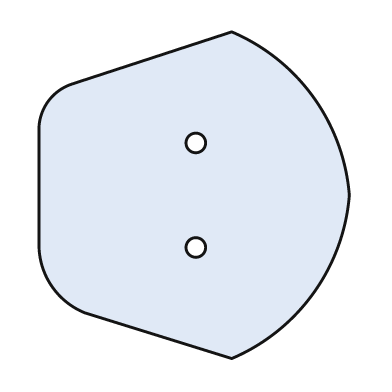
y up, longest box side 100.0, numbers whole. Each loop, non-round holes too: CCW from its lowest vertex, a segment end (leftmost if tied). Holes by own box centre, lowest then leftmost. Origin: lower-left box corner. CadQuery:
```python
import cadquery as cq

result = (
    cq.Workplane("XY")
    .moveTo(59.0, 0.0)
    .threePointArc((84.0, 20.0), (95.0, 50.0))
    .threePointArc((84.0, 80.0), (59.0, 100.0))
    .lineTo(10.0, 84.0)
    .threePointArc((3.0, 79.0), (0.0, 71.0))
    .lineTo(0.0, 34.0)
    .threePointArc((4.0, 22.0), (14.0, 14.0))
    .close()
    .moveTo(48.0, 34.0)
    .circle(3.0)
    .moveTo(48.0, 66.0)
    .circle(3.0)
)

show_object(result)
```